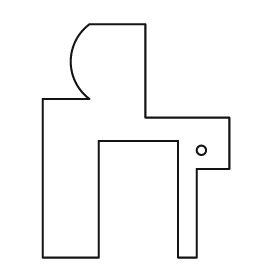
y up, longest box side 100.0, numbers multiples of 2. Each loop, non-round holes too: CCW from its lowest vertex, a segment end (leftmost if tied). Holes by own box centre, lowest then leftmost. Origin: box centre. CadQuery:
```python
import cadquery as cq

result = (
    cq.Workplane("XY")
    .moveTo(-40.0, -50.0)
    .lineTo(-16.0, -50.0)
    .lineTo(-16.0, 0.0)
    .lineTo(18.0, 0.0)
    .lineTo(18.0, -50.0)
    .lineTo(26.0, -50.0)
    .lineTo(26.0, -12.0)
    .lineTo(40.0, -12.0)
    .lineTo(40.0, 10.0)
    .lineTo(4.0, 10.0)
    .lineTo(4.0, 50.0)
    .lineTo(-20.0, 50.0)
    .threePointArc((-28.0, 34.0), (-20.0, 18.0))
    .lineTo(-40.0, 18.0)
    .close()
    .moveTo(28.0, -4.0)
    .circle(2.0)
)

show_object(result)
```